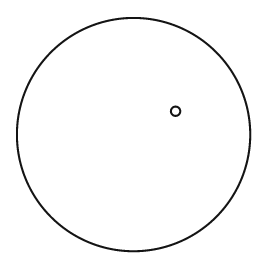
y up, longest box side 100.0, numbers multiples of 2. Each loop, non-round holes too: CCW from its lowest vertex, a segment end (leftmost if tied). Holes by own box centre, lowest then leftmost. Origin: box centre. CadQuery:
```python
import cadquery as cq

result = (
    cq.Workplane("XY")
    .moveTo(0.0, 0.0)
    .circle(50.0)
    .moveTo(18.0, 10.0)
    .circle(2.0)
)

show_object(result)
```